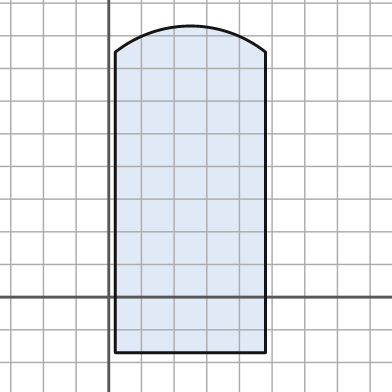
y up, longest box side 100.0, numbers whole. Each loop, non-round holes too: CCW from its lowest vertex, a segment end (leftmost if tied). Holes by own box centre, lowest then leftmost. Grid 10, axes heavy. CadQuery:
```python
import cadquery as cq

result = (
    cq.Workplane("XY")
    .moveTo(2.0, -17.0)
    .lineTo(48.0, -17.0)
    .lineTo(48.0, 75.0)
    .threePointArc((25.0, 83.0), (2.0, 75.0))
    .close()
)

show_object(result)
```